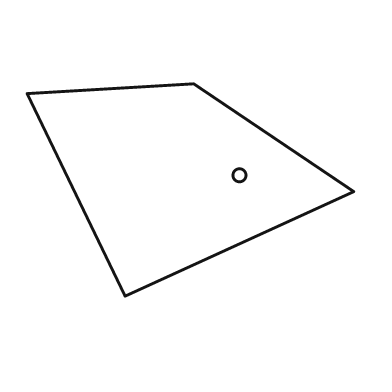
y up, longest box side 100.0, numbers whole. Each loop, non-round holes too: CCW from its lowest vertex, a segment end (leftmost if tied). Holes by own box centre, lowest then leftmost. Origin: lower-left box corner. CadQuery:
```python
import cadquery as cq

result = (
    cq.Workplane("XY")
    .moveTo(30.0, 0.0)
    .lineTo(100.0, 32.0)
    .lineTo(51.0, 65.0)
    .lineTo(0.0, 62.0)
    .close()
    .moveTo(65.0, 37.0)
    .circle(2.0)
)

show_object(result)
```